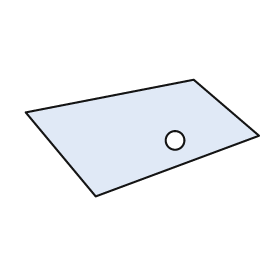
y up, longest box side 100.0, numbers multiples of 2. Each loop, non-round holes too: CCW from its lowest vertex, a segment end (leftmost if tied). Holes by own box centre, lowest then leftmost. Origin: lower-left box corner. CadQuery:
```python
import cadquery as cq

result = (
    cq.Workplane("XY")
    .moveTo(30.0, 0.0)
    .lineTo(100.0, 26.0)
    .lineTo(72.0, 50.0)
    .lineTo(0.0, 36.0)
    .close()
    .moveTo(64.0, 24.0)
    .circle(4.0)
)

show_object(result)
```